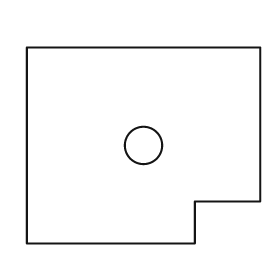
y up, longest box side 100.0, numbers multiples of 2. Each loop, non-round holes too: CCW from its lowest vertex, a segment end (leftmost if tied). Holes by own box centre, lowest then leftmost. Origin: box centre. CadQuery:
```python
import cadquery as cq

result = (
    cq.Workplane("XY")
    .moveTo(-50.0, -42.0)
    .lineTo(22.0, -42.0)
    .lineTo(22.0, -24.0)
    .lineTo(50.0, -24.0)
    .lineTo(50.0, 42.0)
    .lineTo(-50.0, 42.0)
    .close()
    .moveTo(0.0, 0.0)
    .circle(8.0)
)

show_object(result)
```